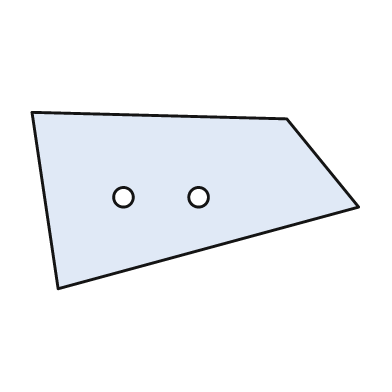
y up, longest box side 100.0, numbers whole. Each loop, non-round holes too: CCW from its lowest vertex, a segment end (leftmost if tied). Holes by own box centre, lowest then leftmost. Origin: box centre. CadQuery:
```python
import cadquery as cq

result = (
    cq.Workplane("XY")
    .moveTo(-42.0, -27.0)
    .lineTo(50.0, -2.0)
    .lineTo(28.0, 25.0)
    .lineTo(-50.0, 27.0)
    .close()
    .moveTo(-22.0, 1.0)
    .circle(3.0)
    .moveTo(1.0, 1.0)
    .circle(3.0)
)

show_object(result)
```